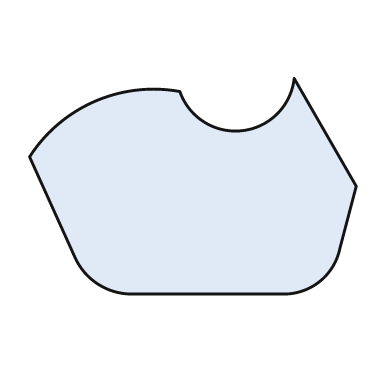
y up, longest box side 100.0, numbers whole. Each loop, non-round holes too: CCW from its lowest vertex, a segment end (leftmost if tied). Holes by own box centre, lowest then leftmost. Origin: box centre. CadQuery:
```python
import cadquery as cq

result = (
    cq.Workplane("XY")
    .moveTo(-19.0, -33.0)
    .lineTo(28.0, -33.0)
    .threePointArc((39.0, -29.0), (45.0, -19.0))
    .lineTo(50.0, 0.0)
    .lineTo(31.0, 33.0)
    .threePointArc((15.0, 17.0), (-4.0, 29.0))
    .threePointArc((-30.0, 26.0), (-50.0, 9.0))
    .lineTo(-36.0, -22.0)
    .threePointArc((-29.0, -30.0), (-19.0, -33.0))
    .close()
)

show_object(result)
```